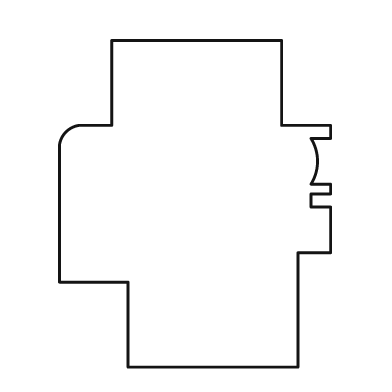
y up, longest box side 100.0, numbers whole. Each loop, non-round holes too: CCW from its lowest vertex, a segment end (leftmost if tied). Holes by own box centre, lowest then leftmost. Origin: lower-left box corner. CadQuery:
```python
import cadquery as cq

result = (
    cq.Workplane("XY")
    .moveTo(21.0, 0.0)
    .lineTo(73.0, 0.0)
    .lineTo(73.0, 35.0)
    .lineTo(83.0, 35.0)
    .lineTo(83.0, 49.0)
    .lineTo(77.0, 49.0)
    .lineTo(77.0, 53.0)
    .lineTo(83.0, 53.0)
    .lineTo(83.0, 56.0)
    .lineTo(77.0, 56.0)
    .threePointArc((79.0, 63.0), (77.0, 70.0))
    .lineTo(83.0, 70.0)
    .lineTo(83.0, 74.0)
    .lineTo(68.0, 74.0)
    .lineTo(68.0, 100.0)
    .lineTo(16.0, 100.0)
    .lineTo(16.0, 74.0)
    .lineTo(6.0, 74.0)
    .threePointArc((2.0, 72.0), (0.0, 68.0))
    .lineTo(0.0, 26.0)
    .lineTo(21.0, 26.0)
    .close()
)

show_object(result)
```